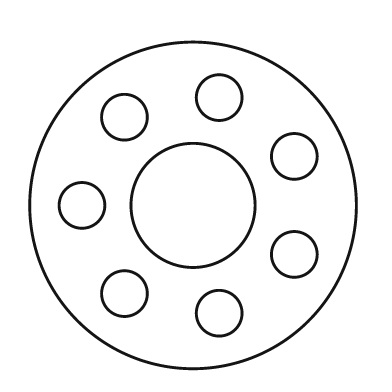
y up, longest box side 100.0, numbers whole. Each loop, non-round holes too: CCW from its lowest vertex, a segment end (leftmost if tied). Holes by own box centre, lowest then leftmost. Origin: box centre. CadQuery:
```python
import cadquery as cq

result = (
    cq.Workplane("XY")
    .moveTo(0.0, 0.0)
    .circle(50.0)
    .moveTo(8.0, -33.0)
    .circle(7.0)
    .moveTo(-21.0, -27.0)
    .circle(7.0)
    .moveTo(31.0, -15.0)
    .circle(7.0)
    .moveTo(-34.0, 0.0)
    .circle(7.0)
    .moveTo(0.0, 0.0)
    .circle(19.0)
    .moveTo(31.0, 15.0)
    .circle(7.0)
    .moveTo(-21.0, 27.0)
    .circle(7.0)
    .moveTo(8.0, 33.0)
    .circle(7.0)
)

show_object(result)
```